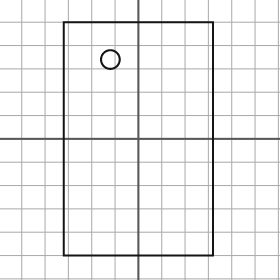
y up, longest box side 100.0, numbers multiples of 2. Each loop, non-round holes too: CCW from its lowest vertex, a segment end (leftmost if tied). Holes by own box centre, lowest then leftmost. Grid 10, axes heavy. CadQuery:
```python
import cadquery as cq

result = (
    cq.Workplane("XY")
    .moveTo(-32.0, -50.0)
    .lineTo(32.0, -50.0)
    .lineTo(32.0, 50.0)
    .lineTo(-32.0, 50.0)
    .close()
    .moveTo(-12.0, 34.0)
    .circle(4.0)
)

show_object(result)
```